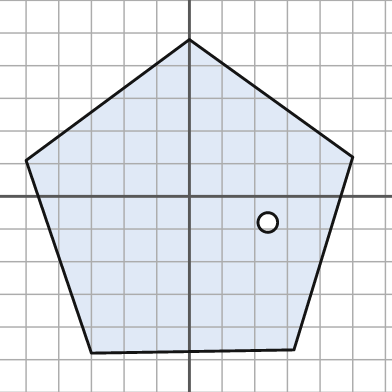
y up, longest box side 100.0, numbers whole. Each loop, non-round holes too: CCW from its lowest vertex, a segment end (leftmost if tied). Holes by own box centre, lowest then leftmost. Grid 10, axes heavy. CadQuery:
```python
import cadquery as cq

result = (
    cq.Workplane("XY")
    .moveTo(-30.0, -48.0)
    .lineTo(32.0, -47.0)
    .lineTo(50.0, 12.0)
    .lineTo(0.0, 48.0)
    .lineTo(-50.0, 11.0)
    .close()
    .moveTo(24.0, -8.0)
    .circle(3.0)
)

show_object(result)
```